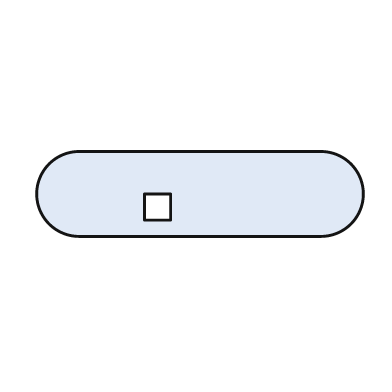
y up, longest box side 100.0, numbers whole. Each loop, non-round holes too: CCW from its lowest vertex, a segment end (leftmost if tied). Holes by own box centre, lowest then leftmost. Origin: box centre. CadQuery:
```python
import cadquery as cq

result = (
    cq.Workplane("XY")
    .moveTo(-37.0, -13.0)
    .lineTo(37.0, -13.0)
    .threePointArc((50.0, 0.0), (37.0, 13.0))
    .lineTo(-37.0, 13.0)
    .threePointArc((-50.0, 0.0), (-37.0, -13.0))
    .close()
    .moveTo(-17.0, -8.0)
    .lineTo(-9.0, -8.0)
    .lineTo(-9.0, 0.0)
    .lineTo(-17.0, 0.0)
    .close()
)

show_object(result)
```